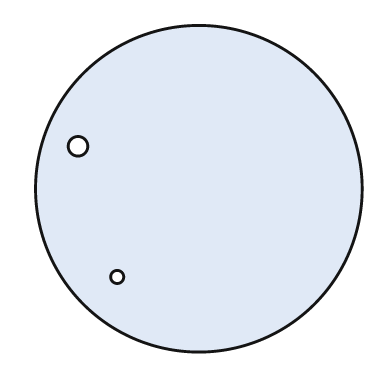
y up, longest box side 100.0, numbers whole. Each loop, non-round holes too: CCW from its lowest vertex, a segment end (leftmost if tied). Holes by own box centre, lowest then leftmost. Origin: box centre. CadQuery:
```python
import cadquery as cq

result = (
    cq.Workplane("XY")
    .moveTo(0.0, 0.0)
    .circle(50.0)
    .moveTo(-25.0, -27.0)
    .circle(2.0)
    .moveTo(-37.0, 13.0)
    .circle(3.0)
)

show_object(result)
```